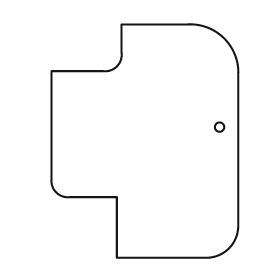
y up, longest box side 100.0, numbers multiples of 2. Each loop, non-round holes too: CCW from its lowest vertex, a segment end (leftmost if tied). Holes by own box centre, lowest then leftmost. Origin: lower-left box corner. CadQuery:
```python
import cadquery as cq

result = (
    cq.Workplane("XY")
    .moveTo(28.0, 0.0)
    .lineTo(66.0, 0.0)
    .threePointArc((76.0, 4.0), (80.0, 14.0))
    .lineTo(80.0, 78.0)
    .threePointArc((74.0, 94.0), (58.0, 100.0))
    .lineTo(30.0, 100.0)
    .lineTo(30.0, 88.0)
    .threePointArc((28.0, 82.0), (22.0, 80.0))
    .lineTo(0.0, 80.0)
    .lineTo(0.0, 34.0)
    .threePointArc((2.0, 28.0), (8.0, 26.0))
    .lineTo(28.0, 26.0)
    .close()
    .moveTo(72.0, 56.0)
    .circle(2.0)
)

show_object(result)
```